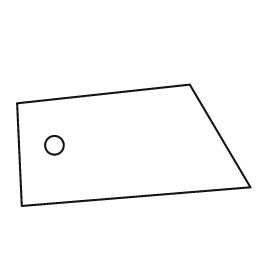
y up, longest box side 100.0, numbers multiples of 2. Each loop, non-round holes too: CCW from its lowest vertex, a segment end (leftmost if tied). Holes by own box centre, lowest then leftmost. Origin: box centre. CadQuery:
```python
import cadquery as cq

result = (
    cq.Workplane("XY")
    .moveTo(-48.0, -26.0)
    .lineTo(50.0, -18.0)
    .lineTo(24.0, 26.0)
    .lineTo(-50.0, 18.0)
    .close()
    .moveTo(-34.0, 0.0)
    .circle(4.0)
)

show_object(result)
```